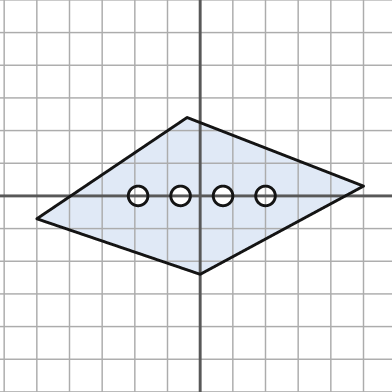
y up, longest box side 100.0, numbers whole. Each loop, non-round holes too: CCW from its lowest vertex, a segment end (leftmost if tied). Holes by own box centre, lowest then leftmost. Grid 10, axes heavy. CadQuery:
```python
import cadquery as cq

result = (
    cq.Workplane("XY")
    .moveTo(0.0, -24.0)
    .lineTo(50.0, 3.0)
    .lineTo(-4.0, 24.0)
    .lineTo(-50.0, -7.0)
    .close()
    .moveTo(-19.0, 0.0)
    .circle(3.0)
    .moveTo(-6.0, 0.0)
    .circle(3.0)
    .moveTo(7.0, 0.0)
    .circle(3.0)
    .moveTo(20.0, 0.0)
    .circle(3.0)
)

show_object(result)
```